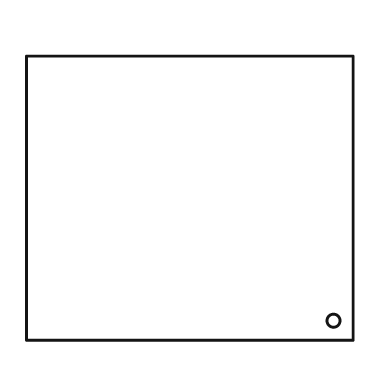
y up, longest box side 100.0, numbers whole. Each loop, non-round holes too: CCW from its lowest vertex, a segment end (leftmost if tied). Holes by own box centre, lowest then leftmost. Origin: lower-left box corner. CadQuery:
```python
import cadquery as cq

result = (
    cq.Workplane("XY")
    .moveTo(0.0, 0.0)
    .lineTo(100.0, 0.0)
    .lineTo(100.0, 87.0)
    .lineTo(0.0, 87.0)
    .close()
    .moveTo(94.0, 6.0)
    .circle(2.0)
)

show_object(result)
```